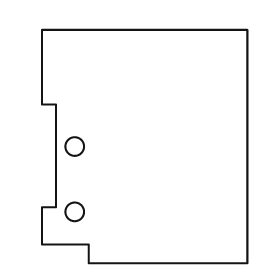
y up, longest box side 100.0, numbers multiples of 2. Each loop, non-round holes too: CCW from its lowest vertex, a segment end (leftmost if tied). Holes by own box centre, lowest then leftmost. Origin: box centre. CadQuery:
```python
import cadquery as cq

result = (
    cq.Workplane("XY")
    .moveTo(-24.0, -50.0)
    .lineTo(44.0, -50.0)
    .lineTo(44.0, 50.0)
    .lineTo(-44.0, 50.0)
    .lineTo(-44.0, 18.0)
    .lineTo(-38.0, 18.0)
    .lineTo(-38.0, -26.0)
    .lineTo(-44.0, -26.0)
    .lineTo(-44.0, -42.0)
    .lineTo(-24.0, -42.0)
    .close()
    .moveTo(-30.0, -28.0)
    .circle(4.0)
    .moveTo(-30.0, 0.0)
    .circle(4.0)
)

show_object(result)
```